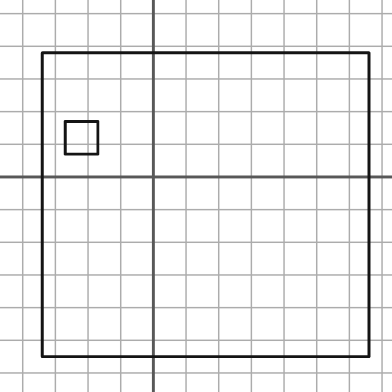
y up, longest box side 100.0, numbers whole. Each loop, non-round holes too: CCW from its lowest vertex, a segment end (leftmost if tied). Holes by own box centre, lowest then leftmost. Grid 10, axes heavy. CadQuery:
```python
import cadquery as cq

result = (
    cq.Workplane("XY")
    .moveTo(-34.0, -55.0)
    .lineTo(66.0, -55.0)
    .lineTo(66.0, 38.0)
    .lineTo(-34.0, 38.0)
    .close()
    .moveTo(-27.0, 7.0)
    .lineTo(-17.0, 7.0)
    .lineTo(-17.0, 17.0)
    .lineTo(-27.0, 17.0)
    .close()
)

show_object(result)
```